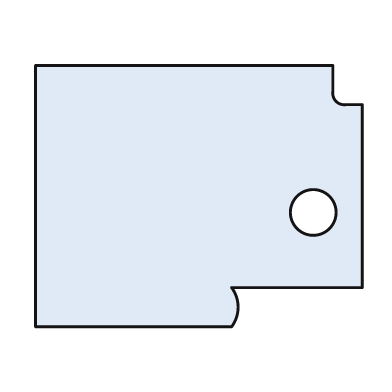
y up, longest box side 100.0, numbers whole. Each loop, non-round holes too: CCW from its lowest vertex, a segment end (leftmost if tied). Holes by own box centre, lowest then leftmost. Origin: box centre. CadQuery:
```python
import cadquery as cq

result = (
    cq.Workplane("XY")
    .moveTo(-50.0, -40.0)
    .lineTo(10.0, -40.0)
    .threePointArc((12.0, -34.0), (10.0, -28.0))
    .lineTo(50.0, -28.0)
    .lineTo(50.0, 28.0)
    .lineTo(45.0, 28.0)
    .threePointArc((42.0, 29.0), (41.0, 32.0))
    .lineTo(41.0, 40.0)
    .lineTo(-50.0, 40.0)
    .close()
    .moveTo(35.0, -5.0)
    .circle(7.0)
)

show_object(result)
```